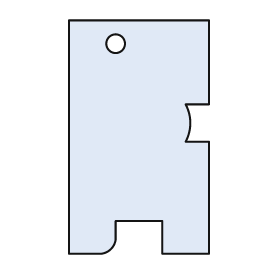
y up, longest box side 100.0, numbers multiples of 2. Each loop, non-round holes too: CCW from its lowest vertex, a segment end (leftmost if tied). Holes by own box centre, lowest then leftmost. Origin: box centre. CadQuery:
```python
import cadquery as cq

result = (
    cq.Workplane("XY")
    .moveTo(-30.0, -50.0)
    .lineTo(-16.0, -50.0)
    .threePointArc((-12.0, -48.0), (-10.0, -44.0))
    .lineTo(-10.0, -36.0)
    .lineTo(10.0, -36.0)
    .lineTo(10.0, -50.0)
    .lineTo(30.0, -50.0)
    .lineTo(30.0, -2.0)
    .lineTo(20.0, -2.0)
    .threePointArc((22.0, 6.0), (20.0, 14.0))
    .lineTo(30.0, 14.0)
    .lineTo(30.0, 50.0)
    .lineTo(-30.0, 50.0)
    .close()
    .moveTo(-10.0, 40.0)
    .circle(4.0)
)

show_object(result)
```